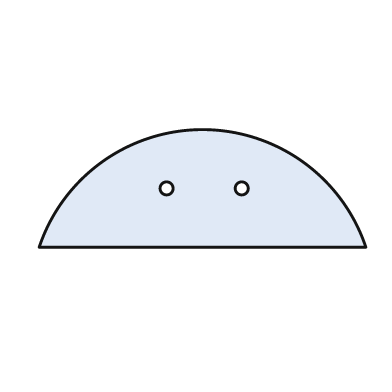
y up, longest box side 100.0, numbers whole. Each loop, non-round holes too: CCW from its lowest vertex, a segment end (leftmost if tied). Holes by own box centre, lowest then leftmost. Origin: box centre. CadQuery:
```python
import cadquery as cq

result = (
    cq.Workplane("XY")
    .moveTo(-50.0, -18.0)
    .lineTo(50.0, -18.0)
    .threePointArc((0.0, 18.0), (-50.0, -18.0))
    .close()
    .moveTo(-11.0, 0.0)
    .circle(2.0)
    .moveTo(12.0, 0.0)
    .circle(2.0)
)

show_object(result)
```